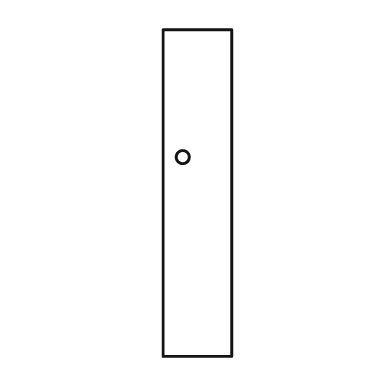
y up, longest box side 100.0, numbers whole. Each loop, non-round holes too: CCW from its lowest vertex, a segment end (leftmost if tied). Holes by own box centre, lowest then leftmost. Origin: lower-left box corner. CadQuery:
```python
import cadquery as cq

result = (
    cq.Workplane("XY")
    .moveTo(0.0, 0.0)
    .lineTo(21.0, 0.0)
    .lineTo(21.0, 100.0)
    .lineTo(0.0, 100.0)
    .close()
    .moveTo(6.0, 61.0)
    .circle(2.0)
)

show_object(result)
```